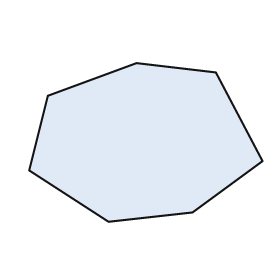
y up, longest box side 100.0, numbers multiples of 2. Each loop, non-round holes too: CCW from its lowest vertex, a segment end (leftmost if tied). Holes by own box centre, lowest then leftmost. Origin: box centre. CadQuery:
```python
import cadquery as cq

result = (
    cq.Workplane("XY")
    .moveTo(-16.0, -34.0)
    .lineTo(20.0, -30.0)
    .lineTo(50.0, -8.0)
    .lineTo(30.0, 30.0)
    .lineTo(-4.0, 34.0)
    .lineTo(-42.0, 20.0)
    .lineTo(-50.0, -12.0)
    .close()
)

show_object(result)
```